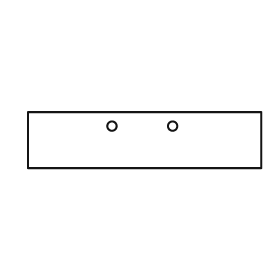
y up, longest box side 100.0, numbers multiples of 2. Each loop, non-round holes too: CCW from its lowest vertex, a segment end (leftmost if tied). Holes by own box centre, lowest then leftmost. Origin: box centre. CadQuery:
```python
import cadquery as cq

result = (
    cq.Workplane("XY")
    .moveTo(-50.0, -12.0)
    .lineTo(50.0, -12.0)
    .lineTo(50.0, 12.0)
    .lineTo(-50.0, 12.0)
    .close()
    .moveTo(-14.0, 6.0)
    .circle(2.0)
    .moveTo(12.0, 6.0)
    .circle(2.0)
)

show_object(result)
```